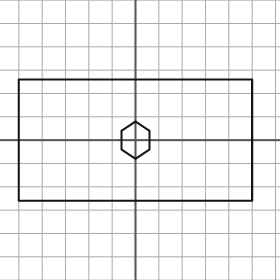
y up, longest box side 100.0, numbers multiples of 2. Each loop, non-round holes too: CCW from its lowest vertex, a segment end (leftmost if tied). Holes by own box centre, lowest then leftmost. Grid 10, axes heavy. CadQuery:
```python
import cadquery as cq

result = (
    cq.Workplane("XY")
    .moveTo(-50.0, -26.0)
    .lineTo(50.0, -26.0)
    .lineTo(50.0, 26.0)
    .lineTo(-50.0, 26.0)
    .close()
    .moveTo(0.0, -8.0)
    .lineTo(6.0, -4.0)
    .lineTo(6.0, 4.0)
    .lineTo(0.0, 8.0)
    .lineTo(-6.0, 4.0)
    .lineTo(-6.0, -4.0)
    .close()
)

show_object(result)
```